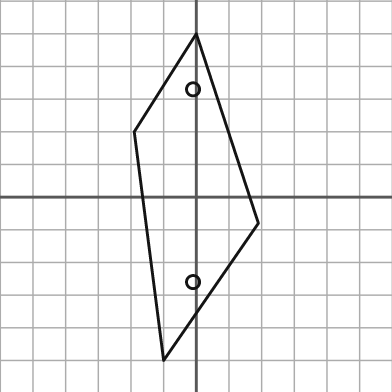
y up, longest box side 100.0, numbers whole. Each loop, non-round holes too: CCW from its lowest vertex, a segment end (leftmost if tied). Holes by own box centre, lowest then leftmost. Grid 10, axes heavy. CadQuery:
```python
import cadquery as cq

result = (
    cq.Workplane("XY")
    .moveTo(-10.0, -50.0)
    .lineTo(19.0, -8.0)
    .lineTo(0.0, 50.0)
    .lineTo(-19.0, 20.0)
    .close()
    .moveTo(-1.0, -26.0)
    .circle(2.0)
    .moveTo(-1.0, 33.0)
    .circle(2.0)
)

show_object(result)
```